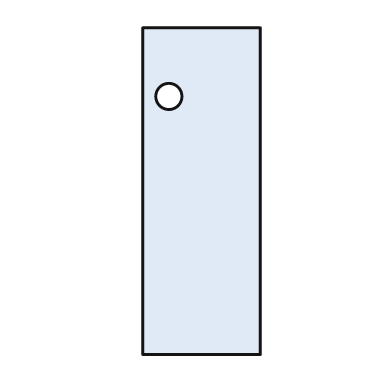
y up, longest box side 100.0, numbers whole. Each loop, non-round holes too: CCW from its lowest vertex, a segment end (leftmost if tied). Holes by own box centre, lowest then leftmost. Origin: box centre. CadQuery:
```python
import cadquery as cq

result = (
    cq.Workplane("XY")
    .moveTo(-18.0, -50.0)
    .lineTo(18.0, -50.0)
    .lineTo(18.0, 50.0)
    .lineTo(-18.0, 50.0)
    .close()
    .moveTo(-10.0, 29.0)
    .circle(4.0)
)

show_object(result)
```